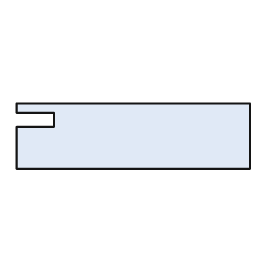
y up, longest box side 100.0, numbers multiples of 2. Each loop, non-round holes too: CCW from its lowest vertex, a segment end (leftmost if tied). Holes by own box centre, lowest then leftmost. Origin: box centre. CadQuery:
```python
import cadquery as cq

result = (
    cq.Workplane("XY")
    .moveTo(-50.0, -14.0)
    .lineTo(50.0, -14.0)
    .lineTo(50.0, 14.0)
    .lineTo(-50.0, 14.0)
    .lineTo(-50.0, 10.0)
    .lineTo(-34.0, 10.0)
    .lineTo(-34.0, 4.0)
    .lineTo(-50.0, 4.0)
    .close()
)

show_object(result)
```